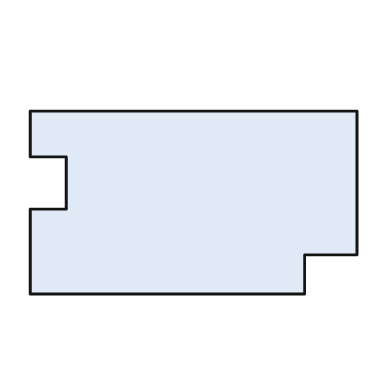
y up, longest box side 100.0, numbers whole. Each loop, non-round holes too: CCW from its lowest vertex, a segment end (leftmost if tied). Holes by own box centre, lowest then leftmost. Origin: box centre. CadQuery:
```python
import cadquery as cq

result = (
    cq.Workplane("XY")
    .moveTo(-50.0, -28.0)
    .lineTo(34.0, -28.0)
    .lineTo(34.0, -16.0)
    .lineTo(50.0, -16.0)
    .lineTo(50.0, 28.0)
    .lineTo(-50.0, 28.0)
    .lineTo(-50.0, 14.0)
    .lineTo(-39.0, 14.0)
    .lineTo(-39.0, -2.0)
    .lineTo(-50.0, -2.0)
    .close()
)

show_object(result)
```